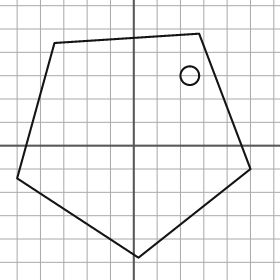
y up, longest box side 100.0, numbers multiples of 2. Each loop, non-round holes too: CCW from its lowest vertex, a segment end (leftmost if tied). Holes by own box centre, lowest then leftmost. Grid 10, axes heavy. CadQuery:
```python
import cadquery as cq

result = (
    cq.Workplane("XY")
    .moveTo(2.0, -48.0)
    .lineTo(50.0, -10.0)
    .lineTo(28.0, 48.0)
    .lineTo(-34.0, 44.0)
    .lineTo(-50.0, -14.0)
    .close()
    .moveTo(24.0, 30.0)
    .circle(4.0)
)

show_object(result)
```